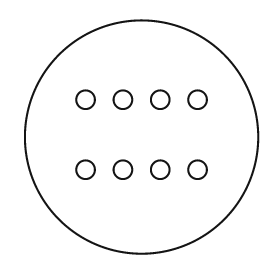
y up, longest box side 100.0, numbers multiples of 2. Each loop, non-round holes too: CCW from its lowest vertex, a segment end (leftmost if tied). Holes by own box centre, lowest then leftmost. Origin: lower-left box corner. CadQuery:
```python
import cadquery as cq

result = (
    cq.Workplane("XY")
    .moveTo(50.0, 50.0)
    .circle(50.0)
    .moveTo(26.0, 36.0)
    .circle(4.0)
    .moveTo(42.0, 36.0)
    .circle(4.0)
    .moveTo(58.0, 36.0)
    .circle(4.0)
    .moveTo(74.0, 36.0)
    .circle(4.0)
    .moveTo(26.0, 66.0)
    .circle(4.0)
    .moveTo(42.0, 66.0)
    .circle(4.0)
    .moveTo(58.0, 66.0)
    .circle(4.0)
    .moveTo(74.0, 66.0)
    .circle(4.0)
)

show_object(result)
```